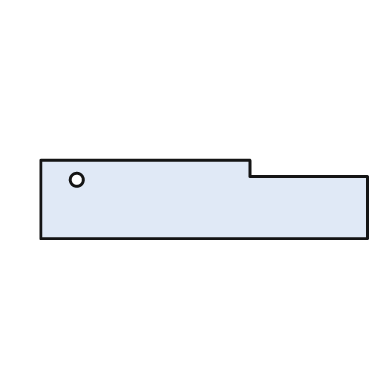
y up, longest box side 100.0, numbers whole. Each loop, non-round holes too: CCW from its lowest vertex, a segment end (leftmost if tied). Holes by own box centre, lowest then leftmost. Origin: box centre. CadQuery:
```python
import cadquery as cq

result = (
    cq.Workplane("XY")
    .moveTo(-50.0, -12.0)
    .lineTo(50.0, -12.0)
    .lineTo(50.0, 7.0)
    .lineTo(14.0, 7.0)
    .lineTo(14.0, 12.0)
    .lineTo(-50.0, 12.0)
    .close()
    .moveTo(-39.0, 6.0)
    .circle(2.0)
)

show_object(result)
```